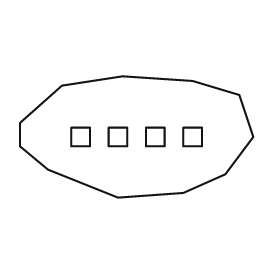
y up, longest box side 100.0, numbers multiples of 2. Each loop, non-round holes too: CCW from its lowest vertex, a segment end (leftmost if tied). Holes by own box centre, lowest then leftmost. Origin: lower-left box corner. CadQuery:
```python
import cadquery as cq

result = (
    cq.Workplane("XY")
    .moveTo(42.0, 0.0)
    .lineTo(70.0, 2.0)
    .lineTo(88.0, 10.0)
    .lineTo(100.0, 26.0)
    .lineTo(94.0, 44.0)
    .lineTo(74.0, 50.0)
    .lineTo(44.0, 52.0)
    .lineTo(18.0, 48.0)
    .lineTo(0.0, 32.0)
    .lineTo(0.0, 22.0)
    .lineTo(12.0, 12.0)
    .close()
    .moveTo(22.0, 22.0)
    .lineTo(30.0, 22.0)
    .lineTo(30.0, 30.0)
    .lineTo(22.0, 30.0)
    .close()
    .moveTo(38.0, 22.0)
    .lineTo(46.0, 22.0)
    .lineTo(46.0, 30.0)
    .lineTo(38.0, 30.0)
    .close()
    .moveTo(54.0, 22.0)
    .lineTo(62.0, 22.0)
    .lineTo(62.0, 30.0)
    .lineTo(54.0, 30.0)
    .close()
    .moveTo(70.0, 22.0)
    .lineTo(78.0, 22.0)
    .lineTo(78.0, 30.0)
    .lineTo(70.0, 30.0)
    .close()
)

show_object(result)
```